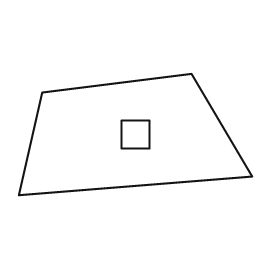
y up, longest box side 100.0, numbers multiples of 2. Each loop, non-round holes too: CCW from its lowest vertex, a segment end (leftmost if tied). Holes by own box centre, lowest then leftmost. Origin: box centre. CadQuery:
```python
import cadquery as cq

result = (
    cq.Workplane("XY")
    .moveTo(-50.0, -26.0)
    .lineTo(50.0, -18.0)
    .lineTo(24.0, 26.0)
    .lineTo(-40.0, 18.0)
    .close()
    .moveTo(-6.0, -6.0)
    .lineTo(6.0, -6.0)
    .lineTo(6.0, 6.0)
    .lineTo(-6.0, 6.0)
    .close()
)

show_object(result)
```